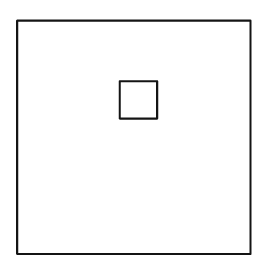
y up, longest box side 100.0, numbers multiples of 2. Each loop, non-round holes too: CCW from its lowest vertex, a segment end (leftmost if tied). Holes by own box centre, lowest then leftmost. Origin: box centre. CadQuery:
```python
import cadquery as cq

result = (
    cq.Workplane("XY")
    .moveTo(-50.0, -50.0)
    .lineTo(50.0, -50.0)
    .lineTo(50.0, 50.0)
    .lineTo(-50.0, 50.0)
    .close()
    .moveTo(-6.0, 8.0)
    .lineTo(10.0, 8.0)
    .lineTo(10.0, 24.0)
    .lineTo(-6.0, 24.0)
    .close()
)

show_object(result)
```